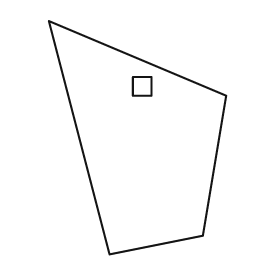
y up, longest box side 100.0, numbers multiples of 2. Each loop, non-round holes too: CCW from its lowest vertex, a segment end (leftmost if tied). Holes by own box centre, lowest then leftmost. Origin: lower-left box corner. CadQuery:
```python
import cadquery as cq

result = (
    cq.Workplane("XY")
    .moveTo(26.0, 0.0)
    .lineTo(66.0, 8.0)
    .lineTo(76.0, 68.0)
    .lineTo(0.0, 100.0)
    .close()
    .moveTo(36.0, 68.0)
    .lineTo(44.0, 68.0)
    .lineTo(44.0, 76.0)
    .lineTo(36.0, 76.0)
    .close()
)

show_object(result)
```